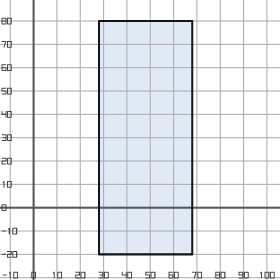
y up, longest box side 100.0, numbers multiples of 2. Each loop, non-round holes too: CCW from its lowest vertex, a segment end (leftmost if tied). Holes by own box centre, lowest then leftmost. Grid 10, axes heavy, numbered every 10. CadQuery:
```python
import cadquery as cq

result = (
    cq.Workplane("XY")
    .moveTo(28.0, -20.0)
    .lineTo(68.0, -20.0)
    .lineTo(68.0, 80.0)
    .lineTo(28.0, 80.0)
    .close()
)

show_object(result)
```